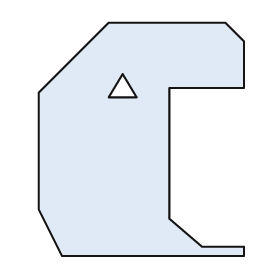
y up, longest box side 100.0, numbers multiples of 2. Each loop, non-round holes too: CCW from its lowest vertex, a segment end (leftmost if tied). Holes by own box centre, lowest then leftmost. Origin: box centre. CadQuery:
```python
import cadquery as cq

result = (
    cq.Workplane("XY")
    .moveTo(-34.0, -50.0)
    .lineTo(44.0, -50.0)
    .lineTo(44.0, -46.0)
    .lineTo(26.0, -46.0)
    .lineTo(12.0, -34.0)
    .lineTo(12.0, 22.0)
    .lineTo(44.0, 22.0)
    .lineTo(44.0, 42.0)
    .lineTo(36.0, 50.0)
    .lineTo(-14.0, 50.0)
    .lineTo(-44.0, 20.0)
    .lineTo(-44.0, -30.0)
    .close()
    .moveTo(-14.0, 18.0)
    .lineTo(-2.0, 18.0)
    .lineTo(-8.0, 28.0)
    .close()
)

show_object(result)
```